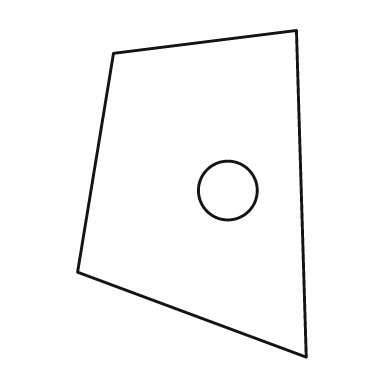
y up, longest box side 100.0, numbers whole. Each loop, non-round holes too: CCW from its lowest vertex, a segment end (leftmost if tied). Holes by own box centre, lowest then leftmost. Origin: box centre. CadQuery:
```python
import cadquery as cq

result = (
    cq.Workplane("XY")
    .moveTo(35.0, -50.0)
    .lineTo(32.0, 50.0)
    .lineTo(-24.0, 43.0)
    .lineTo(-35.0, -24.0)
    .close()
    .moveTo(11.0, 1.0)
    .circle(9.0)
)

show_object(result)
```